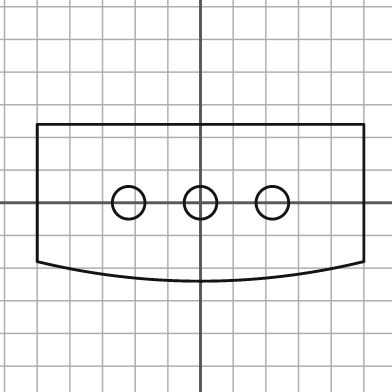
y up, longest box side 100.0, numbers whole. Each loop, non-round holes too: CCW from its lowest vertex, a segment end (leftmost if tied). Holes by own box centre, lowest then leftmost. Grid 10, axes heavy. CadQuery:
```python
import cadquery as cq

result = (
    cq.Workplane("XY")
    .moveTo(-50.0, -18.0)
    .threePointArc((0.0, -24.0), (50.0, -18.0))
    .lineTo(50.0, 24.0)
    .lineTo(-50.0, 24.0)
    .close()
    .moveTo(-22.0, 0.0)
    .circle(5.0)
    .moveTo(0.0, 0.0)
    .circle(5.0)
    .moveTo(22.0, 0.0)
    .circle(5.0)
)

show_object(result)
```